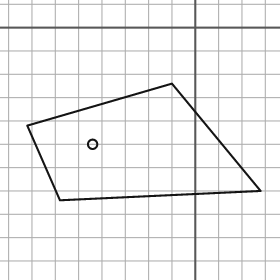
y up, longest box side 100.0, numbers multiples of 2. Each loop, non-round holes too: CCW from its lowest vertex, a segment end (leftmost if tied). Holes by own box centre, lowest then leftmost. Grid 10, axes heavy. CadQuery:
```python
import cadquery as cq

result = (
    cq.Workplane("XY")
    .moveTo(-58.0, -74.0)
    .lineTo(28.0, -70.0)
    .lineTo(-10.0, -24.0)
    .lineTo(-72.0, -42.0)
    .close()
    .moveTo(-44.0, -50.0)
    .circle(2.0)
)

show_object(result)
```